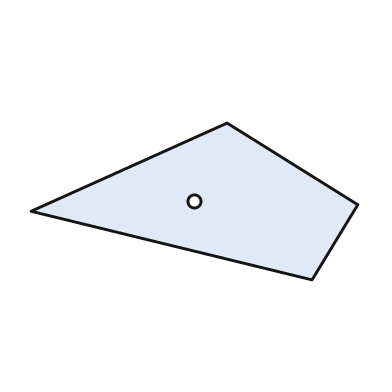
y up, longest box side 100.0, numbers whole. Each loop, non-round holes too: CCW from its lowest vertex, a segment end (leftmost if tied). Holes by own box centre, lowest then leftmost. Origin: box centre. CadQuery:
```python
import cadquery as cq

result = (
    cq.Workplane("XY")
    .moveTo(36.0, -24.0)
    .lineTo(50.0, -1.0)
    .lineTo(10.0, 24.0)
    .lineTo(-50.0, -3.0)
    .close()
    .moveTo(0.0, 0.0)
    .circle(2.0)
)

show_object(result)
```